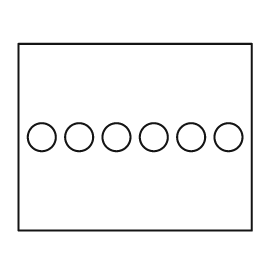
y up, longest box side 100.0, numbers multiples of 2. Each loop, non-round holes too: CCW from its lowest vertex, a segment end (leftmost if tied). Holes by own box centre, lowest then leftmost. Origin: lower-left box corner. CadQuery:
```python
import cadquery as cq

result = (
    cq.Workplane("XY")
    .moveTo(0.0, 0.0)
    .lineTo(100.0, 0.0)
    .lineTo(100.0, 80.0)
    .lineTo(0.0, 80.0)
    .close()
    .moveTo(10.0, 40.0)
    .circle(6.0)
    .moveTo(26.0, 40.0)
    .circle(6.0)
    .moveTo(42.0, 40.0)
    .circle(6.0)
    .moveTo(58.0, 40.0)
    .circle(6.0)
    .moveTo(74.0, 40.0)
    .circle(6.0)
    .moveTo(90.0, 40.0)
    .circle(6.0)
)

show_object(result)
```